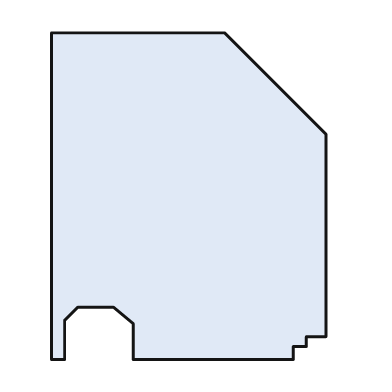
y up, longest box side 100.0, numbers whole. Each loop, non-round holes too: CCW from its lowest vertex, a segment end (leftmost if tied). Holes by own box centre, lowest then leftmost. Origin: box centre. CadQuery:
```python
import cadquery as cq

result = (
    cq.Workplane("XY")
    .moveTo(-42.0, -50.0)
    .lineTo(-38.0, -50.0)
    .lineTo(-38.0, -38.0)
    .lineTo(-34.0, -34.0)
    .lineTo(-23.0, -34.0)
    .lineTo(-17.0, -39.0)
    .lineTo(-17.0, -50.0)
    .lineTo(32.0, -50.0)
    .lineTo(32.0, -46.0)
    .lineTo(36.0, -46.0)
    .lineTo(36.0, -43.0)
    .lineTo(42.0, -43.0)
    .lineTo(42.0, 19.0)
    .lineTo(11.0, 50.0)
    .lineTo(-42.0, 50.0)
    .close()
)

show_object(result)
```